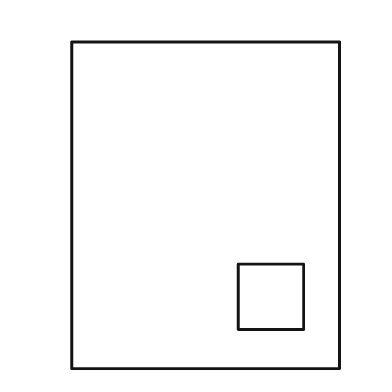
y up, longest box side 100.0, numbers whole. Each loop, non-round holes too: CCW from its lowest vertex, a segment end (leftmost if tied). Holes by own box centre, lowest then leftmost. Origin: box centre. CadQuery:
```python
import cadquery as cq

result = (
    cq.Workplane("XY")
    .moveTo(-41.0, -50.0)
    .lineTo(41.0, -50.0)
    .lineTo(41.0, 50.0)
    .lineTo(-41.0, 50.0)
    .close()
    .moveTo(10.0, -38.0)
    .lineTo(30.0, -38.0)
    .lineTo(30.0, -18.0)
    .lineTo(10.0, -18.0)
    .close()
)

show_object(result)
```